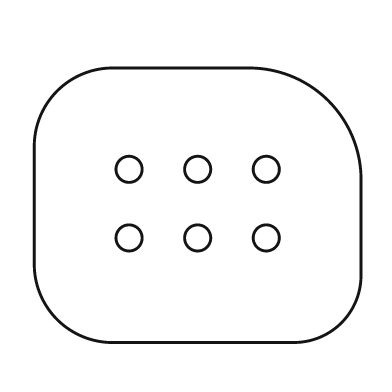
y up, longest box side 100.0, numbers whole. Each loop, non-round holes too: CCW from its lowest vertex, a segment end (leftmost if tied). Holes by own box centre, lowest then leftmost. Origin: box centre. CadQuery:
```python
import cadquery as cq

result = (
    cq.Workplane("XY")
    .moveTo(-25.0, -42.0)
    .lineTo(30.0, -42.0)
    .threePointArc((44.0, -36.0), (50.0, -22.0))
    .lineTo(50.0, 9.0)
    .threePointArc((40.0, 32.0), (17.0, 42.0))
    .lineTo(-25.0, 42.0)
    .threePointArc((-43.0, 35.0), (-50.0, 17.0))
    .lineTo(-50.0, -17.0)
    .threePointArc((-43.0, -35.0), (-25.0, -42.0))
    .close()
    .moveTo(-21.0, -10.0)
    .circle(4.0)
    .moveTo(0.0, -10.0)
    .circle(4.0)
    .moveTo(21.0, -10.0)
    .circle(4.0)
    .moveTo(-21.0, 11.0)
    .circle(4.0)
    .moveTo(0.0, 11.0)
    .circle(4.0)
    .moveTo(21.0, 11.0)
    .circle(4.0)
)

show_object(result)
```